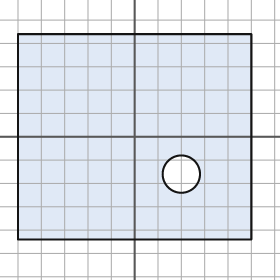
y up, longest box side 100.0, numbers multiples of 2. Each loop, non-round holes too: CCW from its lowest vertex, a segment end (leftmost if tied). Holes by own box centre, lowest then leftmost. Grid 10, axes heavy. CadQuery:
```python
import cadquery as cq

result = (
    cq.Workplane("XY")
    .moveTo(-50.0, -44.0)
    .lineTo(50.0, -44.0)
    .lineTo(50.0, 44.0)
    .lineTo(-50.0, 44.0)
    .close()
    .moveTo(20.0, -16.0)
    .circle(8.0)
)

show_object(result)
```